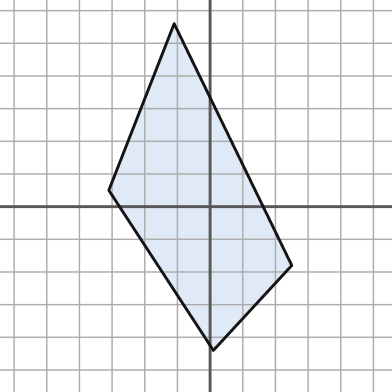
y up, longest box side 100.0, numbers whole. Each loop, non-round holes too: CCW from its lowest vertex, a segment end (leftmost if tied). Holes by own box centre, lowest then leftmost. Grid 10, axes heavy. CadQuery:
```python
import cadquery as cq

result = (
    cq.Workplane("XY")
    .moveTo(1.0, -44.0)
    .lineTo(25.0, -18.0)
    .lineTo(-11.0, 56.0)
    .lineTo(-31.0, 5.0)
    .close()
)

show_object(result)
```